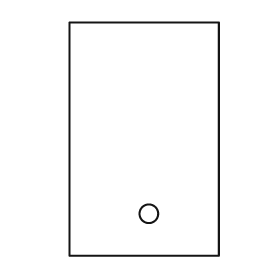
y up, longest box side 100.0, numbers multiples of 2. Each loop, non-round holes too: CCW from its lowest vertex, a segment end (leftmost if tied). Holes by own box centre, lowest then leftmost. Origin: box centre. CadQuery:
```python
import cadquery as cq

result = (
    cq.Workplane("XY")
    .moveTo(-32.0, -50.0)
    .lineTo(32.0, -50.0)
    .lineTo(32.0, 50.0)
    .lineTo(-32.0, 50.0)
    .close()
    .moveTo(2.0, -32.0)
    .circle(4.0)
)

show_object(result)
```